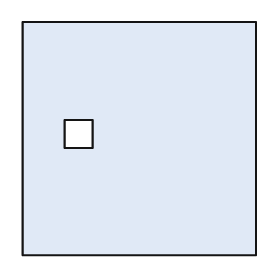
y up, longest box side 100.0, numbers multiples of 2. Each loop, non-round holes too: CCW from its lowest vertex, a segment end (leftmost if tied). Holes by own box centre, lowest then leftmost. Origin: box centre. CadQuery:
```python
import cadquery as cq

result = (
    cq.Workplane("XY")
    .moveTo(-50.0, -50.0)
    .lineTo(50.0, -50.0)
    .lineTo(50.0, 50.0)
    .lineTo(-50.0, 50.0)
    .close()
    .moveTo(-32.0, -4.0)
    .lineTo(-20.0, -4.0)
    .lineTo(-20.0, 8.0)
    .lineTo(-32.0, 8.0)
    .close()
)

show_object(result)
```